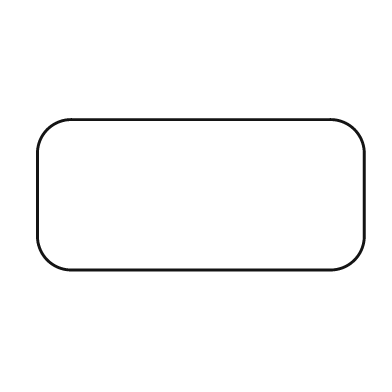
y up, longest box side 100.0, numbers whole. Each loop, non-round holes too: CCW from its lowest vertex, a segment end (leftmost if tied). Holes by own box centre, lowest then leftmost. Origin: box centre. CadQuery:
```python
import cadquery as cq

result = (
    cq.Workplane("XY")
    .moveTo(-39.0, -23.0)
    .lineTo(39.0, -23.0)
    .threePointArc((47.0, -20.0), (50.0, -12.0))
    .lineTo(50.0, 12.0)
    .threePointArc((47.0, 20.0), (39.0, 23.0))
    .lineTo(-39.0, 23.0)
    .threePointArc((-47.0, 20.0), (-50.0, 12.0))
    .lineTo(-50.0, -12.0)
    .threePointArc((-47.0, -20.0), (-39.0, -23.0))
    .close()
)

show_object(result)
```